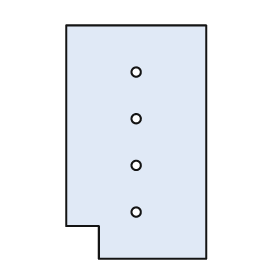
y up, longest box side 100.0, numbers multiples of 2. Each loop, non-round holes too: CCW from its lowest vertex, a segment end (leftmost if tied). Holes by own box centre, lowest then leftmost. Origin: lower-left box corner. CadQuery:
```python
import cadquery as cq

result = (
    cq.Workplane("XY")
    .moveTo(14.0, 0.0)
    .lineTo(60.0, 0.0)
    .lineTo(60.0, 100.0)
    .lineTo(0.0, 100.0)
    .lineTo(0.0, 14.0)
    .lineTo(14.0, 14.0)
    .close()
    .moveTo(30.0, 20.0)
    .circle(2.0)
    .moveTo(30.0, 40.0)
    .circle(2.0)
    .moveTo(30.0, 60.0)
    .circle(2.0)
    .moveTo(30.0, 80.0)
    .circle(2.0)
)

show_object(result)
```